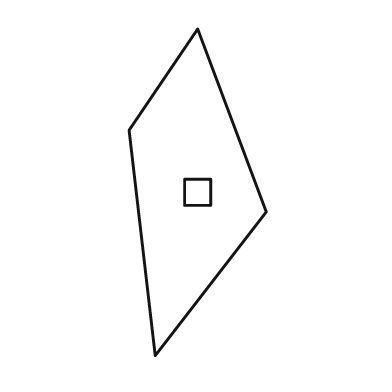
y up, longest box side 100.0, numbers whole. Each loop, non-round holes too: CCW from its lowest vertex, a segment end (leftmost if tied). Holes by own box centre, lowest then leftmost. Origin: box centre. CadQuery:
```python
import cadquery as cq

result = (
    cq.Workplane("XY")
    .moveTo(-13.0, -50.0)
    .lineTo(21.0, -6.0)
    .lineTo(0.0, 50.0)
    .lineTo(-21.0, 19.0)
    .close()
    .moveTo(-4.0, -4.0)
    .lineTo(4.0, -4.0)
    .lineTo(4.0, 4.0)
    .lineTo(-4.0, 4.0)
    .close()
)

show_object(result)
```